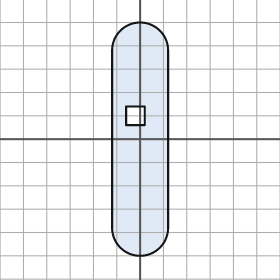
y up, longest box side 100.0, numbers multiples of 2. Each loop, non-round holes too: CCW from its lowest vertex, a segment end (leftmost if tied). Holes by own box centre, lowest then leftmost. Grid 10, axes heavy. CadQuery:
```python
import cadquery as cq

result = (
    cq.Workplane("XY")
    .moveTo(-12.0, -38.0)
    .threePointArc((0.0, -50.0), (12.0, -38.0))
    .lineTo(12.0, 38.0)
    .threePointArc((0.0, 50.0), (-12.0, 38.0))
    .close()
    .moveTo(-6.0, 6.0)
    .lineTo(2.0, 6.0)
    .lineTo(2.0, 14.0)
    .lineTo(-6.0, 14.0)
    .close()
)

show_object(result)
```